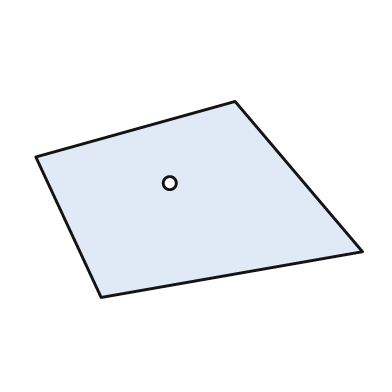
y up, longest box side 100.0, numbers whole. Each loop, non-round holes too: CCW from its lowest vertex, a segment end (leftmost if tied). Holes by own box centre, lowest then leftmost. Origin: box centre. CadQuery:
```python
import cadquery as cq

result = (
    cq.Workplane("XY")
    .moveTo(-30.0, -30.0)
    .lineTo(50.0, -16.0)
    .lineTo(11.0, 30.0)
    .lineTo(-50.0, 13.0)
    .close()
    .moveTo(-9.0, 5.0)
    .circle(2.0)
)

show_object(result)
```